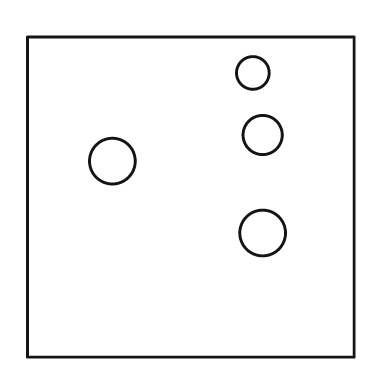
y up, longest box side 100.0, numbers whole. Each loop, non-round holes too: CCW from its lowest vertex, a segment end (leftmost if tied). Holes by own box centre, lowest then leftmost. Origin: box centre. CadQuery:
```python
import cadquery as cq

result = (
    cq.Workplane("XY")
    .moveTo(-50.0, -49.0)
    .lineTo(50.0, -49.0)
    .lineTo(50.0, 49.0)
    .lineTo(-50.0, 49.0)
    .close()
    .moveTo(22.0, -11.0)
    .circle(7.0)
    .moveTo(-24.0, 11.0)
    .circle(7.0)
    .moveTo(22.0, 19.0)
    .circle(6.0)
    .moveTo(19.0, 38.0)
    .circle(5.0)
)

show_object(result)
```